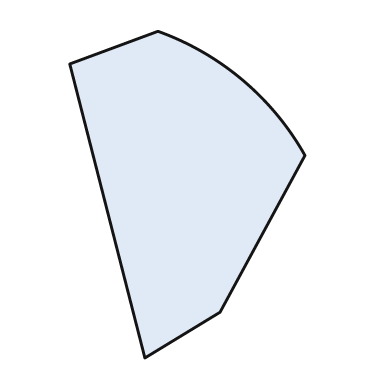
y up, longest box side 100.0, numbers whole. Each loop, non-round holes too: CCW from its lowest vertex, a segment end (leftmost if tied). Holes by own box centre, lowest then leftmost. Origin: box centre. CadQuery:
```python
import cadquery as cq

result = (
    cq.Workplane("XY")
    .moveTo(-13.0, -50.0)
    .lineTo(10.0, -36.0)
    .lineTo(36.0, 12.0)
    .threePointArc((17.0, 35.0), (-9.0, 50.0))
    .lineTo(-36.0, 40.0)
    .close()
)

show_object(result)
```